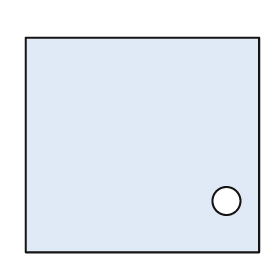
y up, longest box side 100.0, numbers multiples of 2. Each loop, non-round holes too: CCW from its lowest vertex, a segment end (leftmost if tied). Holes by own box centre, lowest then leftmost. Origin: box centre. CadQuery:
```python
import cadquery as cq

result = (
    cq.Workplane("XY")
    .moveTo(-50.0, -46.0)
    .lineTo(50.0, -46.0)
    .lineTo(50.0, 46.0)
    .lineTo(-50.0, 46.0)
    .close()
    .moveTo(36.0, -24.0)
    .circle(6.0)
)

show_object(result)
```